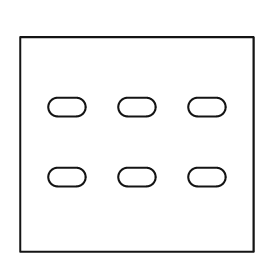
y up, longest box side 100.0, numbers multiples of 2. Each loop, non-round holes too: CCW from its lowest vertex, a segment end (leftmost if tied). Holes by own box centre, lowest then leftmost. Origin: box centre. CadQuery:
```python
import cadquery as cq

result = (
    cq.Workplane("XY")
    .moveTo(-50.0, -46.0)
    .lineTo(50.0, -46.0)
    .lineTo(50.0, 46.0)
    .lineTo(-50.0, 46.0)
    .close()
    .moveTo(-34.0, -18.0)
    .lineTo(-26.0, -18.0)
    .threePointArc((-22.0, -14.0), (-26.0, -10.0))
    .lineTo(-34.0, -10.0)
    .threePointArc((-38.0, -14.0), (-34.0, -18.0))
    .close()
    .moveTo(-4.0, -18.0)
    .lineTo(4.0, -18.0)
    .threePointArc((8.0, -14.0), (4.0, -10.0))
    .lineTo(-4.0, -10.0)
    .threePointArc((-8.0, -14.0), (-4.0, -18.0))
    .close()
    .moveTo(26.0, -18.0)
    .lineTo(34.0, -18.0)
    .threePointArc((38.0, -14.0), (34.0, -10.0))
    .lineTo(26.0, -10.0)
    .threePointArc((22.0, -14.0), (26.0, -18.0))
    .close()
    .moveTo(-34.0, 12.0)
    .lineTo(-26.0, 12.0)
    .threePointArc((-22.0, 16.0), (-26.0, 20.0))
    .lineTo(-34.0, 20.0)
    .threePointArc((-38.0, 16.0), (-34.0, 12.0))
    .close()
    .moveTo(-4.0, 12.0)
    .lineTo(4.0, 12.0)
    .threePointArc((8.0, 16.0), (4.0, 20.0))
    .lineTo(-4.0, 20.0)
    .threePointArc((-8.0, 16.0), (-4.0, 12.0))
    .close()
    .moveTo(26.0, 12.0)
    .lineTo(34.0, 12.0)
    .threePointArc((38.0, 16.0), (34.0, 20.0))
    .lineTo(26.0, 20.0)
    .threePointArc((22.0, 16.0), (26.0, 12.0))
    .close()
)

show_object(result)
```